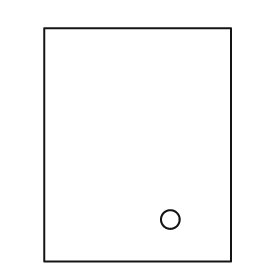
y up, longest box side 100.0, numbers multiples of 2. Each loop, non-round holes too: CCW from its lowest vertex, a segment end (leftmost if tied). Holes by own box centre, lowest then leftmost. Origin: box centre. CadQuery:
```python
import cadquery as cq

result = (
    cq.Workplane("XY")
    .moveTo(-40.0, -50.0)
    .lineTo(40.0, -50.0)
    .lineTo(40.0, 50.0)
    .lineTo(-40.0, 50.0)
    .close()
    .moveTo(14.0, -32.0)
    .circle(4.0)
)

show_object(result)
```